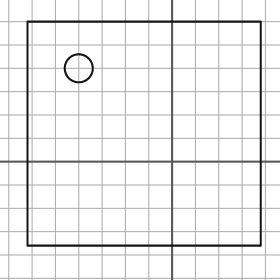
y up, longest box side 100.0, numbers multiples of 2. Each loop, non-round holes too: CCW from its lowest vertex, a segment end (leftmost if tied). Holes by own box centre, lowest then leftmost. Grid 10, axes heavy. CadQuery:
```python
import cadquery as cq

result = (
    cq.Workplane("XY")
    .moveTo(-62.0, -36.0)
    .lineTo(38.0, -36.0)
    .lineTo(38.0, 60.0)
    .lineTo(-62.0, 60.0)
    .close()
    .moveTo(-40.0, 40.0)
    .circle(6.0)
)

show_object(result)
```